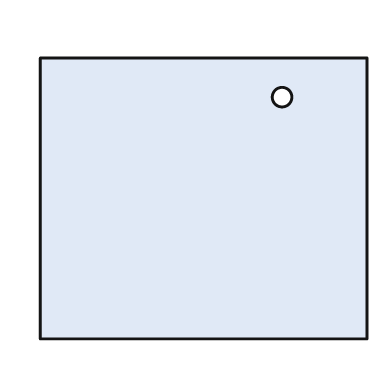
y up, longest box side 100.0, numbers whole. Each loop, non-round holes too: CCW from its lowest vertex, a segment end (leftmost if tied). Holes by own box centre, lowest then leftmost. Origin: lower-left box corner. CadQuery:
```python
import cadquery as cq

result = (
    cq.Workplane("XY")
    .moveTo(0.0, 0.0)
    .lineTo(100.0, 0.0)
    .lineTo(100.0, 86.0)
    .lineTo(0.0, 86.0)
    .close()
    .moveTo(74.0, 74.0)
    .circle(3.0)
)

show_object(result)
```